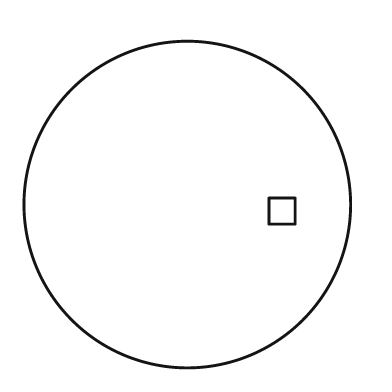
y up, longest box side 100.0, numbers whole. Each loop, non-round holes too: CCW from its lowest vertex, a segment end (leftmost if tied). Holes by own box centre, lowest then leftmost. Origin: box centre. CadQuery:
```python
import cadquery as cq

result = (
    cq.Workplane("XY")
    .moveTo(0.0, 0.0)
    .circle(50.0)
    .moveTo(25.0, -6.0)
    .lineTo(33.0, -6.0)
    .lineTo(33.0, 2.0)
    .lineTo(25.0, 2.0)
    .close()
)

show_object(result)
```